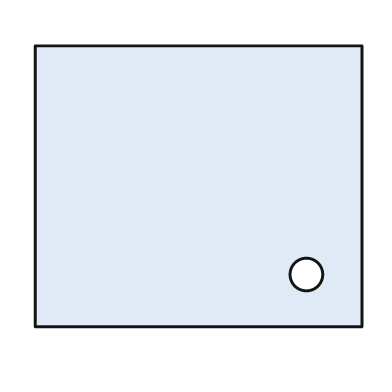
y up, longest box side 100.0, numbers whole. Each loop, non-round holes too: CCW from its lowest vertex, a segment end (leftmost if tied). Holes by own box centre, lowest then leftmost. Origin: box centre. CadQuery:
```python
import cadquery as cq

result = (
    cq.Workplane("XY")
    .moveTo(-50.0, -43.0)
    .lineTo(50.0, -43.0)
    .lineTo(50.0, 43.0)
    .lineTo(-50.0, 43.0)
    .close()
    .moveTo(33.0, -27.0)
    .circle(5.0)
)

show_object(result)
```